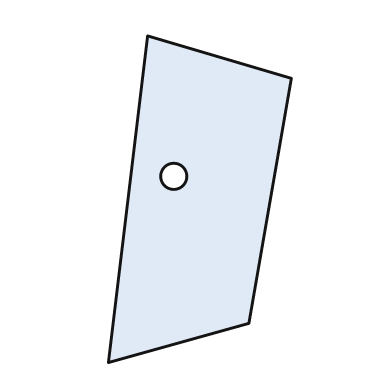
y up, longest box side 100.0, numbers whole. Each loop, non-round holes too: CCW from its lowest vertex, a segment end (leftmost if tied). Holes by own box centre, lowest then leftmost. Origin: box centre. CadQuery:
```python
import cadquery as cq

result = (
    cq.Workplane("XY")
    .moveTo(-28.0, -50.0)
    .lineTo(15.0, -38.0)
    .lineTo(28.0, 37.0)
    .lineTo(-16.0, 50.0)
    .close()
    .moveTo(-8.0, 7.0)
    .circle(4.0)
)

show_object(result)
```